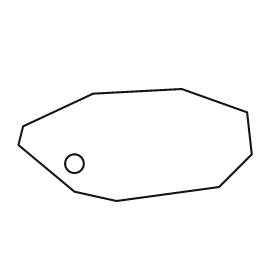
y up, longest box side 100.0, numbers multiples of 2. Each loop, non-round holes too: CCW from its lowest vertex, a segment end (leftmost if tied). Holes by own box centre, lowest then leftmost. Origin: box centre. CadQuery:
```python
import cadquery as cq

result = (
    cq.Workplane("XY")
    .moveTo(-8.0, -24.0)
    .lineTo(36.0, -18.0)
    .lineTo(50.0, -4.0)
    .lineTo(48.0, 14.0)
    .lineTo(20.0, 24.0)
    .lineTo(-18.0, 22.0)
    .lineTo(-48.0, 8.0)
    .lineTo(-50.0, 0.0)
    .lineTo(-26.0, -20.0)
    .close()
    .moveTo(-26.0, -8.0)
    .circle(4.0)
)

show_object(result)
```